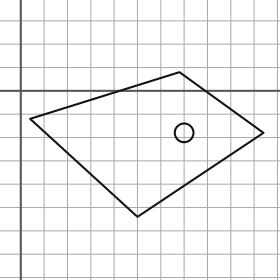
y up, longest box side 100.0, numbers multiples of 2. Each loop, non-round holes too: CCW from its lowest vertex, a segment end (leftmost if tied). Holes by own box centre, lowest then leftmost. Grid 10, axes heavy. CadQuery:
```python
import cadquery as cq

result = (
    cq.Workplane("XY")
    .moveTo(50.0, -54.0)
    .lineTo(104.0, -18.0)
    .lineTo(68.0, 8.0)
    .lineTo(4.0, -12.0)
    .close()
    .moveTo(70.0, -18.0)
    .circle(4.0)
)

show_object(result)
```